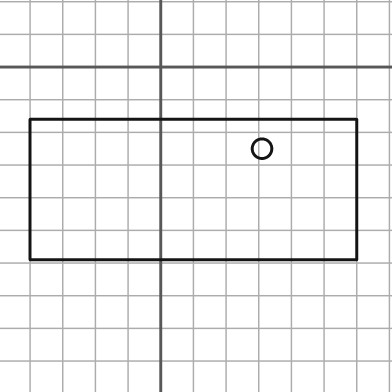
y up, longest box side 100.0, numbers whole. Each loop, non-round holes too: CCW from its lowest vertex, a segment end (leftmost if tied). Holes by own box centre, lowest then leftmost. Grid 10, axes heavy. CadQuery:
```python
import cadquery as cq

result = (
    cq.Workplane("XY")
    .moveTo(-40.0, -59.0)
    .lineTo(60.0, -59.0)
    .lineTo(60.0, -16.0)
    .lineTo(-40.0, -16.0)
    .close()
    .moveTo(31.0, -25.0)
    .circle(3.0)
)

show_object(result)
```